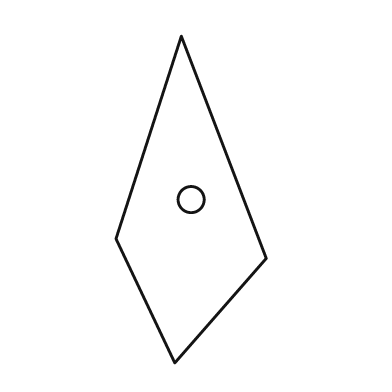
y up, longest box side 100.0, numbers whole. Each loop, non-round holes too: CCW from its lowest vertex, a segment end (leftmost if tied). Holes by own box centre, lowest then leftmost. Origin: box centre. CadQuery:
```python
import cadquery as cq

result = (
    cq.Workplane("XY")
    .moveTo(-5.0, -50.0)
    .lineTo(23.0, -18.0)
    .lineTo(-3.0, 50.0)
    .lineTo(-23.0, -12.0)
    .close()
    .moveTo(0.0, 0.0)
    .circle(4.0)
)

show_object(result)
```